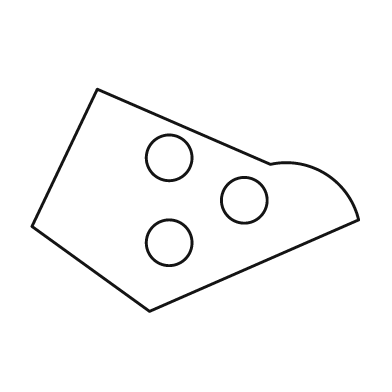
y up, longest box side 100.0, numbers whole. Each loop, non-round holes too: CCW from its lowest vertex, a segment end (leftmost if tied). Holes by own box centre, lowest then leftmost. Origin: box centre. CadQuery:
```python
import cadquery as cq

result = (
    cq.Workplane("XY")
    .moveTo(-14.0, -34.0)
    .lineTo(50.0, -6.0)
    .threePointArc((40.0, 8.0), (23.0, 11.0))
    .lineTo(-30.0, 34.0)
    .lineTo(-50.0, -8.0)
    .close()
    .moveTo(-8.0, -13.0)
    .circle(7.0)
    .moveTo(15.0, 0.0)
    .circle(7.0)
    .moveTo(-8.0, 13.0)
    .circle(7.0)
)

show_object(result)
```